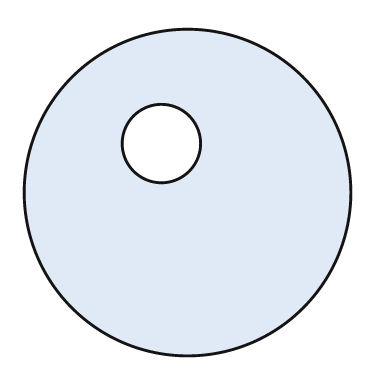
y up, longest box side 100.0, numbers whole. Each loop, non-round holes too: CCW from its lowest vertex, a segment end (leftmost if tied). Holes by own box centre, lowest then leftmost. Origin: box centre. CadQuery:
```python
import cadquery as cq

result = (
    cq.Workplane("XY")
    .moveTo(0.0, 0.0)
    .circle(50.0)
    .moveTo(-8.0, 15.0)
    .circle(12.0)
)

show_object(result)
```